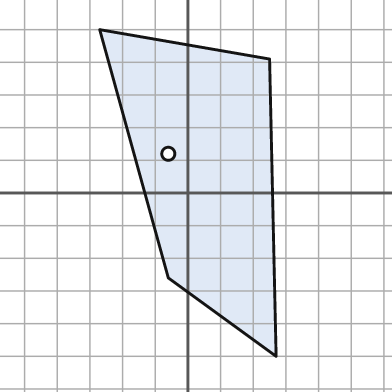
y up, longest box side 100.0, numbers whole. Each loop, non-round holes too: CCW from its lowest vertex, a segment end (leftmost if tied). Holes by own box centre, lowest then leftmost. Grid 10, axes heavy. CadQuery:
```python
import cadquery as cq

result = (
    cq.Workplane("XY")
    .moveTo(27.0, -50.0)
    .lineTo(25.0, 41.0)
    .lineTo(-27.0, 50.0)
    .lineTo(-6.0, -26.0)
    .close()
    .moveTo(-6.0, 12.0)
    .circle(2.0)
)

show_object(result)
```